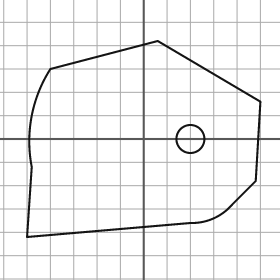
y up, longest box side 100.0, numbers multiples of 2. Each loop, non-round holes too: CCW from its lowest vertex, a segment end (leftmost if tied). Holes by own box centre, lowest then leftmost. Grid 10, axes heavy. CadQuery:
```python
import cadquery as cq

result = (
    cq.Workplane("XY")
    .moveTo(-50.0, -42.0)
    .lineTo(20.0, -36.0)
    .threePointArc((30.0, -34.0), (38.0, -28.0))
    .lineTo(48.0, -18.0)
    .lineTo(50.0, 16.0)
    .lineTo(6.0, 42.0)
    .lineTo(-40.0, 30.0)
    .threePointArc((-48.0, 10.0), (-48.0, -12.0))
    .close()
    .moveTo(20.0, 0.0)
    .circle(6.0)
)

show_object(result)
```